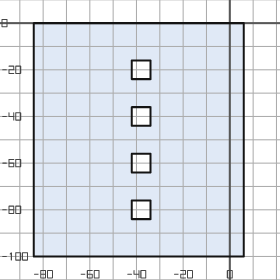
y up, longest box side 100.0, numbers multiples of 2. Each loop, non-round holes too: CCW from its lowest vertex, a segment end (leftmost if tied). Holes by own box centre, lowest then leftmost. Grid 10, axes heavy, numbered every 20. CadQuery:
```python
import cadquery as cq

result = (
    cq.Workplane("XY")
    .moveTo(-84.0, -100.0)
    .lineTo(6.0, -100.0)
    .lineTo(6.0, 0.0)
    .lineTo(-84.0, 0.0)
    .close()
    .moveTo(-42.0, -84.0)
    .lineTo(-34.0, -84.0)
    .lineTo(-34.0, -76.0)
    .lineTo(-42.0, -76.0)
    .close()
    .moveTo(-42.0, -64.0)
    .lineTo(-34.0, -64.0)
    .lineTo(-34.0, -56.0)
    .lineTo(-42.0, -56.0)
    .close()
    .moveTo(-42.0, -44.0)
    .lineTo(-34.0, -44.0)
    .lineTo(-34.0, -36.0)
    .lineTo(-42.0, -36.0)
    .close()
    .moveTo(-42.0, -24.0)
    .lineTo(-34.0, -24.0)
    .lineTo(-34.0, -16.0)
    .lineTo(-42.0, -16.0)
    .close()
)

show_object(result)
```